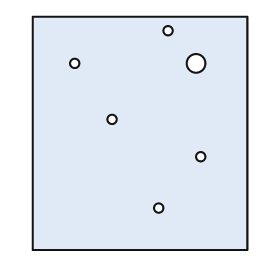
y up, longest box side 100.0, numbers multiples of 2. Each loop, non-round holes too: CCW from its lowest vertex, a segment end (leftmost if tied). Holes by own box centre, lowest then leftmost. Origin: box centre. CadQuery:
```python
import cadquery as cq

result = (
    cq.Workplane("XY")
    .moveTo(-46.0, -50.0)
    .lineTo(46.0, -50.0)
    .lineTo(46.0, 50.0)
    .lineTo(-46.0, 50.0)
    .close()
    .moveTo(8.0, -32.0)
    .circle(2.0)
    .moveTo(26.0, -10.0)
    .circle(2.0)
    .moveTo(-12.0, 6.0)
    .circle(2.0)
    .moveTo(-28.0, 30.0)
    .circle(2.0)
    .moveTo(24.0, 30.0)
    .circle(4.0)
    .moveTo(12.0, 44.0)
    .circle(2.0)
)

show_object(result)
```